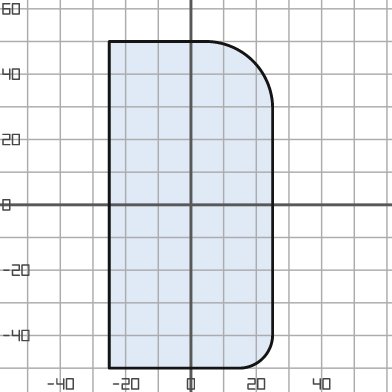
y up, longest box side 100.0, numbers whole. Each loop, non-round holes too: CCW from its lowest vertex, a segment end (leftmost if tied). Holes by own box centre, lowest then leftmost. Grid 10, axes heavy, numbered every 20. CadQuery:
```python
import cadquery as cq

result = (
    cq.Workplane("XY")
    .moveTo(-25.0, -50.0)
    .lineTo(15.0, -50.0)
    .threePointArc((22.0, -47.0), (25.0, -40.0))
    .lineTo(25.0, 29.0)
    .threePointArc((19.0, 44.0), (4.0, 50.0))
    .lineTo(-25.0, 50.0)
    .close()
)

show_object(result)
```